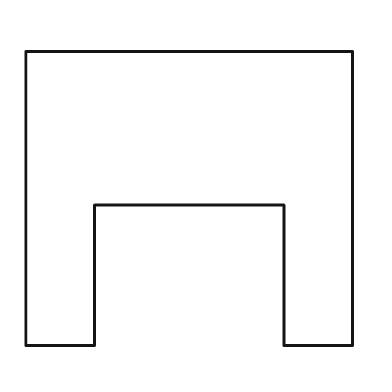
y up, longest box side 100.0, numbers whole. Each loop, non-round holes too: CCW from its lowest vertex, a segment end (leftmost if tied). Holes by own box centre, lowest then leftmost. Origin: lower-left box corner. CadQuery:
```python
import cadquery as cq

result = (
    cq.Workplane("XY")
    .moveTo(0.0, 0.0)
    .lineTo(21.0, 0.0)
    .lineTo(21.0, 43.0)
    .lineTo(79.0, 43.0)
    .lineTo(79.0, 0.0)
    .lineTo(100.0, 0.0)
    .lineTo(100.0, 90.0)
    .lineTo(0.0, 90.0)
    .close()
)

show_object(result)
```